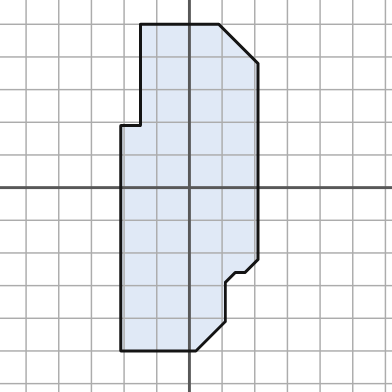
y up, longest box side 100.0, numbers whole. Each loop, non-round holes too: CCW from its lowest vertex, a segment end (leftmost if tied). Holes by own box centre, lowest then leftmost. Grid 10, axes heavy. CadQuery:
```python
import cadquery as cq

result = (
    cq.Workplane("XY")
    .moveTo(-21.0, -50.0)
    .lineTo(2.0, -50.0)
    .lineTo(11.0, -41.0)
    .lineTo(11.0, -29.0)
    .lineTo(14.0, -26.0)
    .lineTo(17.0, -26.0)
    .lineTo(21.0, -22.0)
    .lineTo(21.0, 38.0)
    .lineTo(9.0, 50.0)
    .lineTo(-15.0, 50.0)
    .lineTo(-15.0, 19.0)
    .lineTo(-21.0, 19.0)
    .close()
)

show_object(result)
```